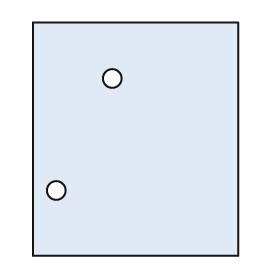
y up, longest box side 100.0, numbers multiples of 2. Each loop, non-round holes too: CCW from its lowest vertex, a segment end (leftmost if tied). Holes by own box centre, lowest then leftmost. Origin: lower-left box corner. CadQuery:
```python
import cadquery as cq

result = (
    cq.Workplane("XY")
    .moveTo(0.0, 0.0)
    .lineTo(88.0, 0.0)
    .lineTo(88.0, 100.0)
    .lineTo(0.0, 100.0)
    .close()
    .moveTo(10.0, 28.0)
    .circle(4.0)
    .moveTo(34.0, 76.0)
    .circle(4.0)
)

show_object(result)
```